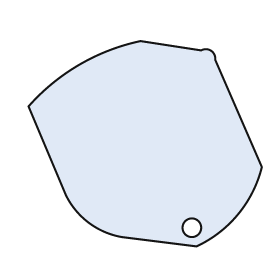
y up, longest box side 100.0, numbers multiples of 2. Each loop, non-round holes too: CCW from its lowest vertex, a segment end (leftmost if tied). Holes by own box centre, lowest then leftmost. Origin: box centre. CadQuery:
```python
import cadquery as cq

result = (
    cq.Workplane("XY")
    .moveTo(22.0, -44.0)
    .threePointArc((40.0, -30.0), (50.0, -10.0))
    .lineTo(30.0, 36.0)
    .threePointArc((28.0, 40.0), (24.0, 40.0))
    .lineTo(-2.0, 44.0)
    .threePointArc((-28.0, 34.0), (-50.0, 16.0))
    .lineTo(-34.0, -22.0)
    .threePointArc((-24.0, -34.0), (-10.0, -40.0))
    .close()
    .moveTo(20.0, -36.0)
    .circle(4.0)
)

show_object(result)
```